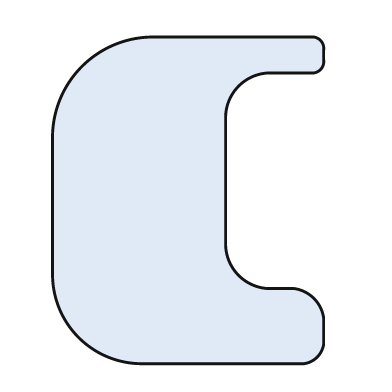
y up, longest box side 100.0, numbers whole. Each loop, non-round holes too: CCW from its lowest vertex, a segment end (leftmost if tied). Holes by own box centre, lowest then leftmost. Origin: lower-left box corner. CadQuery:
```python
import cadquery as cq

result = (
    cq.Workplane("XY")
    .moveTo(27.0, 0.0)
    .lineTo(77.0, 0.0)
    .threePointArc((81.0, 2.0), (83.0, 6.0))
    .lineTo(83.0, 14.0)
    .threePointArc((80.0, 20.0), (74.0, 23.0))
    .lineTo(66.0, 23.0)
    .threePointArc((57.0, 27.0), (53.0, 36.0))
    .lineTo(53.0, 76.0)
    .threePointArc((57.0, 85.0), (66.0, 89.0))
    .lineTo(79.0, 89.0)
    .threePointArc((82.0, 90.0), (83.0, 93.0))
    .lineTo(83.0, 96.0)
    .threePointArc((82.0, 99.0), (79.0, 100.0))
    .lineTo(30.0, 100.0)
    .threePointArc((9.0, 91.0), (0.0, 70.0))
    .lineTo(0.0, 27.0)
    .threePointArc((8.0, 8.0), (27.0, 0.0))
    .close()
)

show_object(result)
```